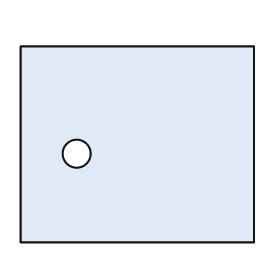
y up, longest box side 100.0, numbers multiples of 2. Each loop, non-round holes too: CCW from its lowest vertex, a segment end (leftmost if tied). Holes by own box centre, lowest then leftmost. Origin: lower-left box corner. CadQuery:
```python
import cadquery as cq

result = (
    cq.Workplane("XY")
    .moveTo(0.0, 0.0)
    .lineTo(100.0, 0.0)
    .lineTo(100.0, 84.0)
    .lineTo(0.0, 84.0)
    .close()
    .moveTo(24.0, 38.0)
    .circle(6.0)
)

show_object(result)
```